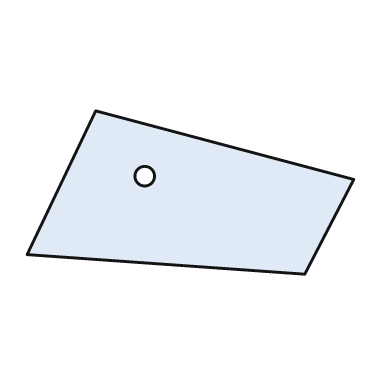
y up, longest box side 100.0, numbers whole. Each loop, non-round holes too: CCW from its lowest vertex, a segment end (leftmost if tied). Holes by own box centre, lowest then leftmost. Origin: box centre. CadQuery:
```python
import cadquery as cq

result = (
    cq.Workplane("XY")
    .moveTo(35.0, -25.0)
    .lineTo(50.0, 4.0)
    .lineTo(-29.0, 25.0)
    .lineTo(-50.0, -19.0)
    .close()
    .moveTo(-14.0, 5.0)
    .circle(3.0)
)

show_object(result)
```